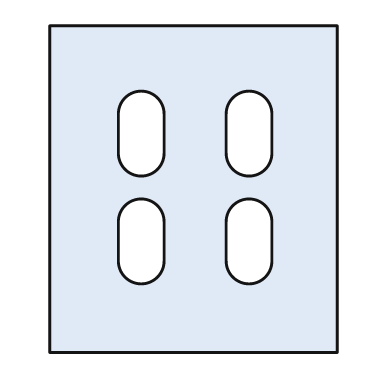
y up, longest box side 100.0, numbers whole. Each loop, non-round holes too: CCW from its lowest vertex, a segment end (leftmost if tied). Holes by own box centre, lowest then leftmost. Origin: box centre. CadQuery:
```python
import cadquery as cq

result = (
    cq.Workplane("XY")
    .moveTo(-44.0, -50.0)
    .lineTo(44.0, -50.0)
    .lineTo(44.0, 50.0)
    .lineTo(-44.0, 50.0)
    .close()
    .moveTo(-23.0, -22.0)
    .threePointArc((-16.0, -29.0), (-9.0, -22.0))
    .lineTo(-9.0, -10.0)
    .threePointArc((-16.0, -3.0), (-23.0, -10.0))
    .close()
    .moveTo(10.0, -22.0)
    .threePointArc((17.0, -29.0), (24.0, -22.0))
    .lineTo(24.0, -10.0)
    .threePointArc((17.0, -3.0), (10.0, -10.0))
    .close()
    .moveTo(-23.0, 11.0)
    .threePointArc((-16.0, 4.0), (-9.0, 11.0))
    .lineTo(-9.0, 23.0)
    .threePointArc((-16.0, 30.0), (-23.0, 23.0))
    .close()
    .moveTo(10.0, 11.0)
    .threePointArc((17.0, 4.0), (24.0, 11.0))
    .lineTo(24.0, 23.0)
    .threePointArc((17.0, 30.0), (10.0, 23.0))
    .close()
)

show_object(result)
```